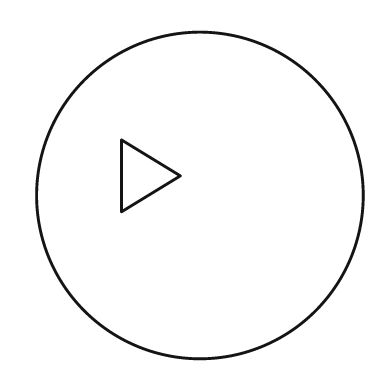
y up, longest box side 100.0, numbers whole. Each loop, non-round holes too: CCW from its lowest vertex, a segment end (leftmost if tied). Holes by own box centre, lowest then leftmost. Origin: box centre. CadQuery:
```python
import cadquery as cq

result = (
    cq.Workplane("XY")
    .moveTo(0.0, 0.0)
    .circle(50.0)
    .moveTo(-24.0, -5.0)
    .lineTo(-6.0, 6.0)
    .lineTo(-24.0, 17.0)
    .close()
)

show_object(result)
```